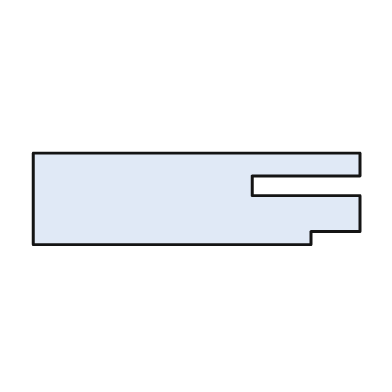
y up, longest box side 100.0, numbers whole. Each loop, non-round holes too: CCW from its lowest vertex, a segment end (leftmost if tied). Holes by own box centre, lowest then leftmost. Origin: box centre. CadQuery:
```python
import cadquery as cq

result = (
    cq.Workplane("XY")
    .moveTo(-50.0, -14.0)
    .lineTo(35.0, -14.0)
    .lineTo(35.0, -10.0)
    .lineTo(50.0, -10.0)
    .lineTo(50.0, 1.0)
    .lineTo(17.0, 1.0)
    .lineTo(17.0, 7.0)
    .lineTo(50.0, 7.0)
    .lineTo(50.0, 14.0)
    .lineTo(-50.0, 14.0)
    .close()
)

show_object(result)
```